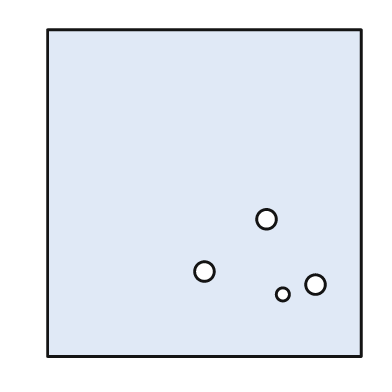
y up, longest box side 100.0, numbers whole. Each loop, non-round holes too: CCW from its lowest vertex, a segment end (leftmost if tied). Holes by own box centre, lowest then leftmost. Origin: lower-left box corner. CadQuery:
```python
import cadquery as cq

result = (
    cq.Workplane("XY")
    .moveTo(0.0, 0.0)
    .lineTo(96.0, 0.0)
    .lineTo(96.0, 100.0)
    .lineTo(0.0, 100.0)
    .close()
    .moveTo(72.0, 19.0)
    .circle(2.0)
    .moveTo(82.0, 22.0)
    .circle(3.0)
    .moveTo(48.0, 26.0)
    .circle(3.0)
    .moveTo(67.0, 42.0)
    .circle(3.0)
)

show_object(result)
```